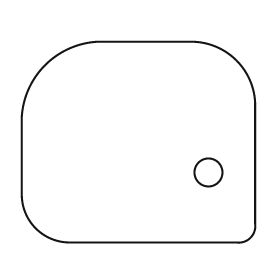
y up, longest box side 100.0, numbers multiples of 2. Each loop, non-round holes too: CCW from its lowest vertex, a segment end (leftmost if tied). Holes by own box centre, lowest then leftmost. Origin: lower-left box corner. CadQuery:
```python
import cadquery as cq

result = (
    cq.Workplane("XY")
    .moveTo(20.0, 0.0)
    .lineTo(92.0, 0.0)
    .threePointArc((98.0, 2.0), (100.0, 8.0))
    .lineTo(100.0, 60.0)
    .threePointArc((92.0, 78.0), (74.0, 86.0))
    .lineTo(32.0, 86.0)
    .threePointArc((10.0, 76.0), (0.0, 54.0))
    .lineTo(0.0, 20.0)
    .threePointArc((6.0, 6.0), (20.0, 0.0))
    .close()
    .moveTo(80.0, 30.0)
    .circle(6.0)
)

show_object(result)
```